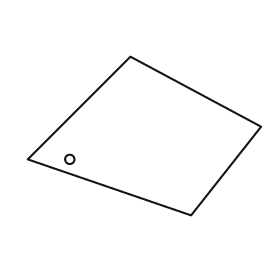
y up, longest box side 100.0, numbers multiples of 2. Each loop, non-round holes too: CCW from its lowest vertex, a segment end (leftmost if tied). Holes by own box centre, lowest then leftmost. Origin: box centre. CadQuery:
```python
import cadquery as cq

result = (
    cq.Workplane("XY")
    .moveTo(20.0, -34.0)
    .lineTo(50.0, 4.0)
    .lineTo(-6.0, 34.0)
    .lineTo(-50.0, -10.0)
    .close()
    .moveTo(-32.0, -10.0)
    .circle(2.0)
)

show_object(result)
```